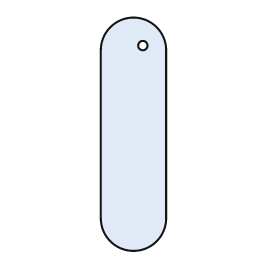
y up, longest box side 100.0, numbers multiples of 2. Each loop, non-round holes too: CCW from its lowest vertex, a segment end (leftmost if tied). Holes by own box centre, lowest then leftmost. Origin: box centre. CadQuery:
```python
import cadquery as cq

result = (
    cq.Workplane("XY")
    .moveTo(-14.0, -36.0)
    .threePointArc((0.0, -50.0), (14.0, -36.0))
    .lineTo(14.0, 36.0)
    .threePointArc((0.0, 50.0), (-14.0, 36.0))
    .close()
    .moveTo(4.0, 38.0)
    .circle(2.0)
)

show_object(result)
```